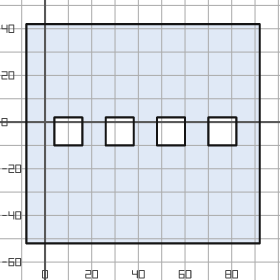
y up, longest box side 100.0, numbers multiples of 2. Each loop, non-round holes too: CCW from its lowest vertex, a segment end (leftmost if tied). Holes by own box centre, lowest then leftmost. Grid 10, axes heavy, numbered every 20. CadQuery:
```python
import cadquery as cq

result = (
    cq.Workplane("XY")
    .moveTo(-8.0, -52.0)
    .lineTo(92.0, -52.0)
    .lineTo(92.0, 42.0)
    .lineTo(-8.0, 42.0)
    .close()
    .moveTo(4.0, -10.0)
    .lineTo(16.0, -10.0)
    .lineTo(16.0, 2.0)
    .lineTo(4.0, 2.0)
    .close()
    .moveTo(26.0, -10.0)
    .lineTo(38.0, -10.0)
    .lineTo(38.0, 2.0)
    .lineTo(26.0, 2.0)
    .close()
    .moveTo(48.0, -10.0)
    .lineTo(60.0, -10.0)
    .lineTo(60.0, 2.0)
    .lineTo(48.0, 2.0)
    .close()
    .moveTo(70.0, -10.0)
    .lineTo(82.0, -10.0)
    .lineTo(82.0, 2.0)
    .lineTo(70.0, 2.0)
    .close()
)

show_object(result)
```